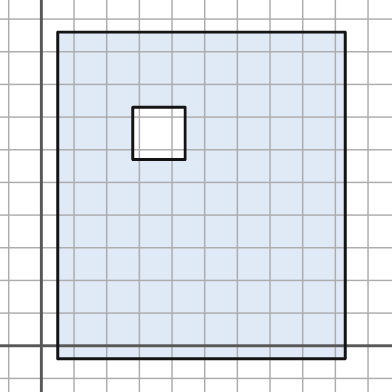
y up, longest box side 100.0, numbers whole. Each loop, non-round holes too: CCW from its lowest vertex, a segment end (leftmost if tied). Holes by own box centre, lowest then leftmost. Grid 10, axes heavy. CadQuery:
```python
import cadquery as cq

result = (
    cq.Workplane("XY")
    .moveTo(5.0, -4.0)
    .lineTo(93.0, -4.0)
    .lineTo(93.0, 96.0)
    .lineTo(5.0, 96.0)
    .close()
    .moveTo(28.0, 57.0)
    .lineTo(44.0, 57.0)
    .lineTo(44.0, 73.0)
    .lineTo(28.0, 73.0)
    .close()
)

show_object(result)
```